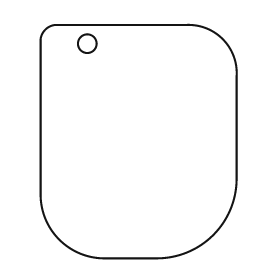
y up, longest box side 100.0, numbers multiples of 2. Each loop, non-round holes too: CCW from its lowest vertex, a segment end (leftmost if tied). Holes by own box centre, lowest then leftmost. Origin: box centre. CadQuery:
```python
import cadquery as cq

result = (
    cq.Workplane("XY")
    .moveTo(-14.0, -50.0)
    .lineTo(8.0, -50.0)
    .threePointArc((32.0, -40.0), (42.0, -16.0))
    .lineTo(42.0, 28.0)
    .threePointArc((36.0, 44.0), (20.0, 50.0))
    .lineTo(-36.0, 50.0)
    .threePointArc((-40.0, 48.0), (-42.0, 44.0))
    .lineTo(-42.0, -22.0)
    .threePointArc((-34.0, -42.0), (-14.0, -50.0))
    .close()
    .moveTo(-22.0, 42.0)
    .circle(4.0)
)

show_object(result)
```